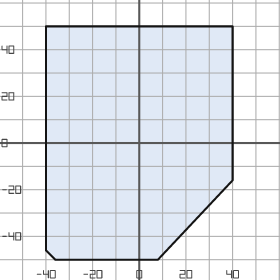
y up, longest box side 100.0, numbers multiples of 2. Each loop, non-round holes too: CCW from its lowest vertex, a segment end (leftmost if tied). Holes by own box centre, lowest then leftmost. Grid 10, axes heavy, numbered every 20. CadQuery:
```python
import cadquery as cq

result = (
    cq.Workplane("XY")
    .moveTo(-36.0, -50.0)
    .lineTo(8.0, -50.0)
    .lineTo(40.0, -16.0)
    .lineTo(40.0, 50.0)
    .lineTo(-40.0, 50.0)
    .lineTo(-40.0, -46.0)
    .close()
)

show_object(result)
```